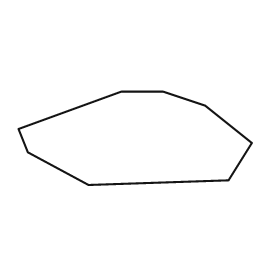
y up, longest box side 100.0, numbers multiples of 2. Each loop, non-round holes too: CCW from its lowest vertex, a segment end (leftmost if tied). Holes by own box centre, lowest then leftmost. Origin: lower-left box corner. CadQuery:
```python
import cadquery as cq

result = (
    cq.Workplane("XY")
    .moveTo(30.0, 0.0)
    .lineTo(90.0, 2.0)
    .lineTo(100.0, 18.0)
    .lineTo(80.0, 34.0)
    .lineTo(62.0, 40.0)
    .lineTo(44.0, 40.0)
    .lineTo(0.0, 24.0)
    .lineTo(4.0, 14.0)
    .close()
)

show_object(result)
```